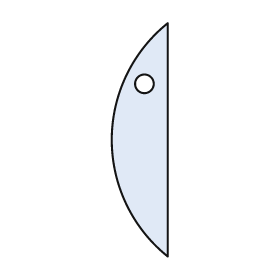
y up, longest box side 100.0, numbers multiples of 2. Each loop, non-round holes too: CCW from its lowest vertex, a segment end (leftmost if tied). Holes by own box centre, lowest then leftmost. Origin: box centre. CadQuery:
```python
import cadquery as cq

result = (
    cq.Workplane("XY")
    .moveTo(12.0, -50.0)
    .lineTo(12.0, 50.0)
    .threePointArc((-12.0, 0.0), (12.0, -50.0))
    .close()
    .moveTo(2.0, 24.0)
    .circle(4.0)
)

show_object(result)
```